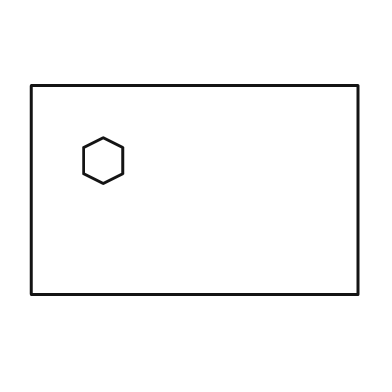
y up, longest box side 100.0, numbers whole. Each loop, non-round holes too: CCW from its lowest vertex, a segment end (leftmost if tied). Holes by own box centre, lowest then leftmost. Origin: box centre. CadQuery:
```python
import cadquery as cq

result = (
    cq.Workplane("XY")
    .moveTo(-50.0, -32.0)
    .lineTo(50.0, -32.0)
    .lineTo(50.0, 32.0)
    .lineTo(-50.0, 32.0)
    .close()
    .moveTo(-28.0, 2.0)
    .lineTo(-22.0, 5.0)
    .lineTo(-22.0, 13.0)
    .lineTo(-28.0, 16.0)
    .lineTo(-34.0, 13.0)
    .lineTo(-34.0, 5.0)
    .close()
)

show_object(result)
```